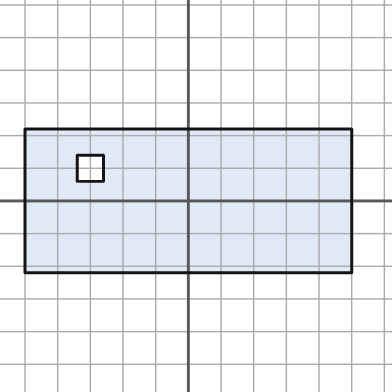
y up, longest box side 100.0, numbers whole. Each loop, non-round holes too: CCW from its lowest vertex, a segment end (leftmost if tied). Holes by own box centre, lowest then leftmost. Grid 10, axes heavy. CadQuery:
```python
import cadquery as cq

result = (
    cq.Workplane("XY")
    .moveTo(-50.0, -22.0)
    .lineTo(50.0, -22.0)
    .lineTo(50.0, 22.0)
    .lineTo(-50.0, 22.0)
    .close()
    .moveTo(-34.0, 6.0)
    .lineTo(-26.0, 6.0)
    .lineTo(-26.0, 14.0)
    .lineTo(-34.0, 14.0)
    .close()
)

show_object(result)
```